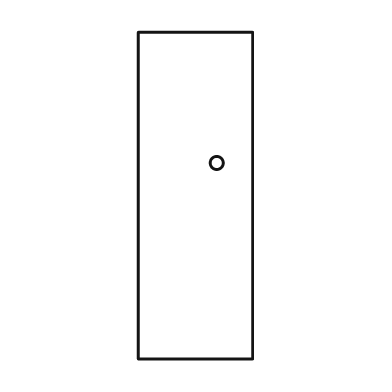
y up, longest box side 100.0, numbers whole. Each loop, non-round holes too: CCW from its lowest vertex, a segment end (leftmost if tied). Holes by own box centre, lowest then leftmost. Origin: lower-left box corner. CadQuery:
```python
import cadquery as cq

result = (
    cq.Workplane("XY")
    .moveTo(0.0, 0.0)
    .lineTo(35.0, 0.0)
    .lineTo(35.0, 100.0)
    .lineTo(0.0, 100.0)
    .close()
    .moveTo(24.0, 60.0)
    .circle(2.0)
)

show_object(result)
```